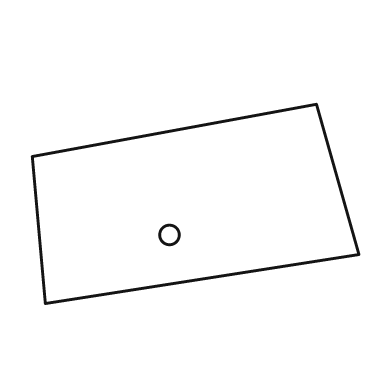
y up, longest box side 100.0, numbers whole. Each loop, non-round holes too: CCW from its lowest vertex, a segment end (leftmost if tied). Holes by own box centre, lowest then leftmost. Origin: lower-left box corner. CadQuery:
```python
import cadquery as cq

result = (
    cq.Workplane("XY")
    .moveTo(4.0, 0.0)
    .lineTo(100.0, 15.0)
    .lineTo(87.0, 61.0)
    .lineTo(0.0, 45.0)
    .close()
    .moveTo(42.0, 21.0)
    .circle(3.0)
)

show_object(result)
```